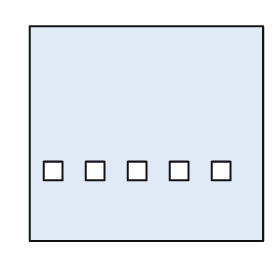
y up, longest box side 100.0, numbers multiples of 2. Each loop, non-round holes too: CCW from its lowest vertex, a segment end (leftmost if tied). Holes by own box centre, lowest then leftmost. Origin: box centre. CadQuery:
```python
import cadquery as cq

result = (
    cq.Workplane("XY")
    .moveTo(-50.0, -46.0)
    .lineTo(50.0, -46.0)
    .lineTo(50.0, 46.0)
    .lineTo(-50.0, 46.0)
    .close()
    .moveTo(-44.0, -20.0)
    .lineTo(-36.0, -20.0)
    .lineTo(-36.0, -12.0)
    .lineTo(-44.0, -12.0)
    .close()
    .moveTo(-26.0, -20.0)
    .lineTo(-18.0, -20.0)
    .lineTo(-18.0, -12.0)
    .lineTo(-26.0, -12.0)
    .close()
    .moveTo(-8.0, -20.0)
    .lineTo(0.0, -20.0)
    .lineTo(0.0, -12.0)
    .lineTo(-8.0, -12.0)
    .close()
    .moveTo(10.0, -20.0)
    .lineTo(18.0, -20.0)
    .lineTo(18.0, -12.0)
    .lineTo(10.0, -12.0)
    .close()
    .moveTo(28.0, -20.0)
    .lineTo(36.0, -20.0)
    .lineTo(36.0, -12.0)
    .lineTo(28.0, -12.0)
    .close()
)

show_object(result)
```